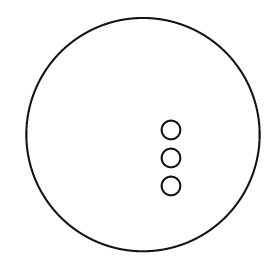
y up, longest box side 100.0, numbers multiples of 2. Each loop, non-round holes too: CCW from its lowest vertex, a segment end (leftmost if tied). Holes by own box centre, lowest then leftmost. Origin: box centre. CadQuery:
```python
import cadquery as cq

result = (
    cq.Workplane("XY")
    .moveTo(0.0, 0.0)
    .circle(50.0)
    .moveTo(12.0, -22.0)
    .circle(4.0)
    .moveTo(12.0, -10.0)
    .circle(4.0)
    .moveTo(12.0, 2.0)
    .circle(4.0)
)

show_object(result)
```